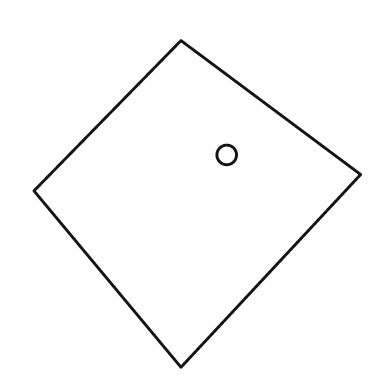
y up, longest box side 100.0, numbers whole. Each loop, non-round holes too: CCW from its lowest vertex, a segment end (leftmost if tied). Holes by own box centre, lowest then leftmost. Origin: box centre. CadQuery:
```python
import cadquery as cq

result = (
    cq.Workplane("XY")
    .moveTo(-5.0, -50.0)
    .lineTo(50.0, 9.0)
    .lineTo(-5.0, 50.0)
    .lineTo(-50.0, 4.0)
    .close()
    .moveTo(9.0, 15.0)
    .circle(3.0)
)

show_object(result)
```